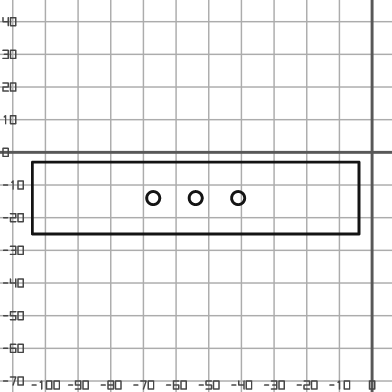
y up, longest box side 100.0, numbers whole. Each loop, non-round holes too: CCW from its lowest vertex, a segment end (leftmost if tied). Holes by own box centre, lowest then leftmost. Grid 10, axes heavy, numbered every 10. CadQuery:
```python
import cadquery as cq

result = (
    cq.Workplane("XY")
    .moveTo(-104.0, -25.0)
    .lineTo(-4.0, -25.0)
    .lineTo(-4.0, -3.0)
    .lineTo(-104.0, -3.0)
    .close()
    .moveTo(-67.0, -14.0)
    .circle(2.0)
    .moveTo(-54.0, -14.0)
    .circle(2.0)
    .moveTo(-41.0, -14.0)
    .circle(2.0)
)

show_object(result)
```